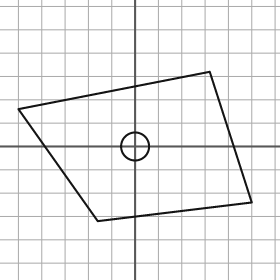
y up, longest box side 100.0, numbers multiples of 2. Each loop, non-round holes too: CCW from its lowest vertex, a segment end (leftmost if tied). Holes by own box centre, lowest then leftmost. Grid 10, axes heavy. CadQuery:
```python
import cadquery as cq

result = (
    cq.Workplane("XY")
    .moveTo(-16.0, -32.0)
    .lineTo(50.0, -24.0)
    .lineTo(32.0, 32.0)
    .lineTo(-50.0, 16.0)
    .close()
    .moveTo(0.0, 0.0)
    .circle(6.0)
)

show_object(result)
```